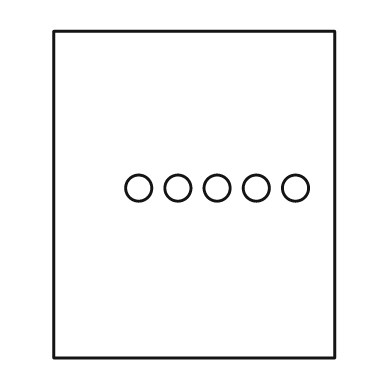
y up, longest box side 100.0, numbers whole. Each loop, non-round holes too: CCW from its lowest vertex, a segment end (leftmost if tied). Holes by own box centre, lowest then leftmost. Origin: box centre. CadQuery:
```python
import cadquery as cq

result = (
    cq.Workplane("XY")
    .moveTo(-43.0, -50.0)
    .lineTo(43.0, -50.0)
    .lineTo(43.0, 50.0)
    .lineTo(-43.0, 50.0)
    .close()
    .moveTo(-17.0, 2.0)
    .circle(4.0)
    .moveTo(-5.0, 2.0)
    .circle(4.0)
    .moveTo(7.0, 2.0)
    .circle(4.0)
    .moveTo(19.0, 2.0)
    .circle(4.0)
    .moveTo(31.0, 2.0)
    .circle(4.0)
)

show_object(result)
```